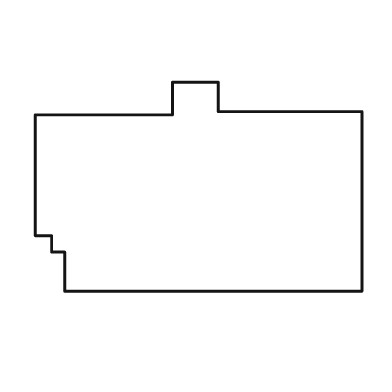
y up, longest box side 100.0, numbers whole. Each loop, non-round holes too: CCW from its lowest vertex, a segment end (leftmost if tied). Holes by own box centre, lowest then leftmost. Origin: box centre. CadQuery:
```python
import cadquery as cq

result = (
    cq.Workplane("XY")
    .moveTo(-41.0, -32.0)
    .lineTo(50.0, -32.0)
    .lineTo(50.0, 23.0)
    .lineTo(6.0, 23.0)
    .lineTo(6.0, 32.0)
    .lineTo(-8.0, 32.0)
    .lineTo(-8.0, 22.0)
    .lineTo(-50.0, 22.0)
    .lineTo(-50.0, -15.0)
    .lineTo(-45.0, -15.0)
    .lineTo(-45.0, -20.0)
    .lineTo(-41.0, -20.0)
    .close()
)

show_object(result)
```